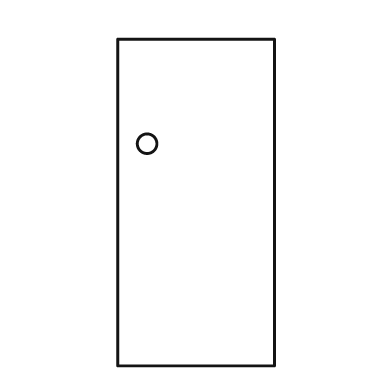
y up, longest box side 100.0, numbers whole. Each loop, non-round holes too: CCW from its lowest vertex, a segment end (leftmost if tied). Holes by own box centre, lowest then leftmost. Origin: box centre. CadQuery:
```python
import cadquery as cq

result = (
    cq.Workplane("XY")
    .moveTo(-24.0, -50.0)
    .lineTo(24.0, -50.0)
    .lineTo(24.0, 50.0)
    .lineTo(-24.0, 50.0)
    .close()
    .moveTo(-15.0, 18.0)
    .circle(3.0)
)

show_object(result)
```